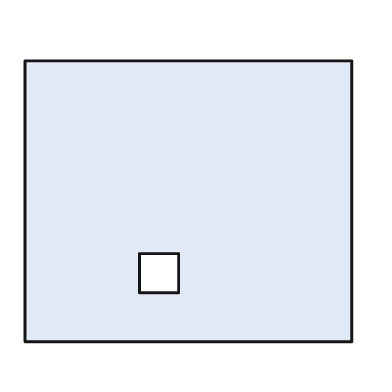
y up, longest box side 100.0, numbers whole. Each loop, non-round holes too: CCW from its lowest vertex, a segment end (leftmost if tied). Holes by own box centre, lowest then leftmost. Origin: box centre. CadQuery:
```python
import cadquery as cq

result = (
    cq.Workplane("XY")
    .moveTo(-50.0, -43.0)
    .lineTo(50.0, -43.0)
    .lineTo(50.0, 43.0)
    .lineTo(-50.0, 43.0)
    .close()
    .moveTo(-15.0, -28.0)
    .lineTo(-3.0, -28.0)
    .lineTo(-3.0, -16.0)
    .lineTo(-15.0, -16.0)
    .close()
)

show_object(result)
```